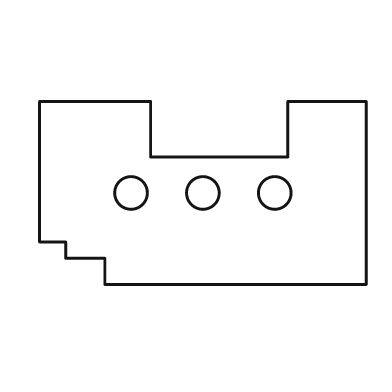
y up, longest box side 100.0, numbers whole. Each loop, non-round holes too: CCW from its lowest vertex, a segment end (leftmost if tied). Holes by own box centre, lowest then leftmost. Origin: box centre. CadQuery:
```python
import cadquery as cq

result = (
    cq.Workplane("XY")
    .moveTo(-30.0, -28.0)
    .lineTo(50.0, -28.0)
    .lineTo(50.0, 28.0)
    .lineTo(26.0, 28.0)
    .lineTo(26.0, 11.0)
    .lineTo(-16.0, 11.0)
    .lineTo(-16.0, 28.0)
    .lineTo(-50.0, 28.0)
    .lineTo(-50.0, -15.0)
    .lineTo(-42.0, -15.0)
    .lineTo(-42.0, -20.0)
    .lineTo(-30.0, -20.0)
    .close()
    .moveTo(-22.0, 0.0)
    .circle(5.0)
    .moveTo(0.0, 0.0)
    .circle(5.0)
    .moveTo(22.0, 0.0)
    .circle(5.0)
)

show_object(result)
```